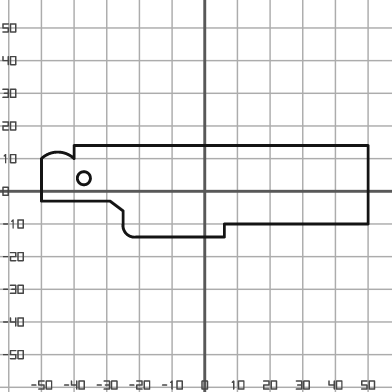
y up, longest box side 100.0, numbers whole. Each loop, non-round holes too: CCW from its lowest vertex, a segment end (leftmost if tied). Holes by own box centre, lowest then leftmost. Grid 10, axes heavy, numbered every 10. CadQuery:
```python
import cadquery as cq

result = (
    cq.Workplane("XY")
    .moveTo(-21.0, -14.0)
    .lineTo(6.0, -14.0)
    .lineTo(6.0, -10.0)
    .lineTo(50.0, -10.0)
    .lineTo(50.0, 14.0)
    .lineTo(-40.0, 14.0)
    .lineTo(-40.0, 10.0)
    .threePointArc((-45.0, 12.0), (-50.0, 10.0))
    .lineTo(-50.0, -3.0)
    .lineTo(-29.0, -3.0)
    .lineTo(-25.0, -6.0)
    .lineTo(-25.0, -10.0)
    .threePointArc((-24.0, -13.0), (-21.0, -14.0))
    .close()
    .moveTo(-37.0, 4.0)
    .circle(2.0)
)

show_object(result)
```